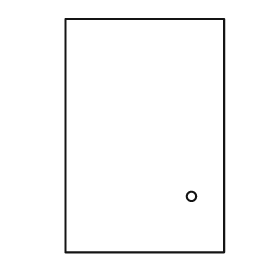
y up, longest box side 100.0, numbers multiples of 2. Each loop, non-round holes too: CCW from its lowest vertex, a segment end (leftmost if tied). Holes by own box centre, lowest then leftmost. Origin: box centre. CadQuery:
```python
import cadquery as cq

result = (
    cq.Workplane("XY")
    .moveTo(-34.0, -50.0)
    .lineTo(34.0, -50.0)
    .lineTo(34.0, 50.0)
    .lineTo(-34.0, 50.0)
    .close()
    .moveTo(20.0, -26.0)
    .circle(2.0)
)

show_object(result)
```